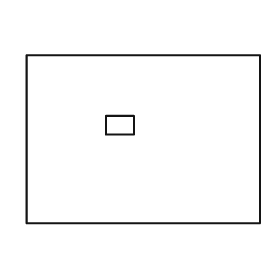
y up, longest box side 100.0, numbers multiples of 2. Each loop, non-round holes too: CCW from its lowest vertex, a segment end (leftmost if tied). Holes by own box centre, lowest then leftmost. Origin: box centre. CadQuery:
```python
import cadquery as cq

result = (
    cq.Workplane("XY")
    .moveTo(-50.0, -36.0)
    .lineTo(50.0, -36.0)
    .lineTo(50.0, 36.0)
    .lineTo(-50.0, 36.0)
    .close()
    .moveTo(-16.0, 2.0)
    .lineTo(-4.0, 2.0)
    .lineTo(-4.0, 10.0)
    .lineTo(-16.0, 10.0)
    .close()
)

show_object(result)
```